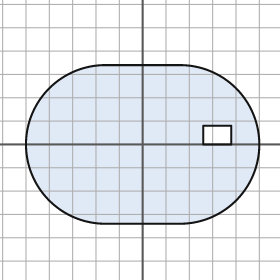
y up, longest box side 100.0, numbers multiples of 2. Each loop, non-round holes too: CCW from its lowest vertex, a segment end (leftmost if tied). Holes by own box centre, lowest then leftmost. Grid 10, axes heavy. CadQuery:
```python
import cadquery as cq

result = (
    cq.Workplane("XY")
    .moveTo(-16.0, -34.0)
    .lineTo(16.0, -34.0)
    .threePointArc((50.0, 0.0), (16.0, 34.0))
    .lineTo(-16.0, 34.0)
    .threePointArc((-50.0, 0.0), (-16.0, -34.0))
    .close()
    .moveTo(26.0, 0.0)
    .lineTo(38.0, 0.0)
    .lineTo(38.0, 8.0)
    .lineTo(26.0, 8.0)
    .close()
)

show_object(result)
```